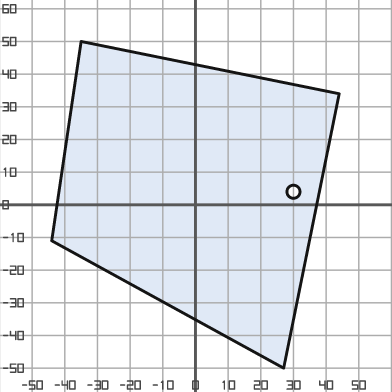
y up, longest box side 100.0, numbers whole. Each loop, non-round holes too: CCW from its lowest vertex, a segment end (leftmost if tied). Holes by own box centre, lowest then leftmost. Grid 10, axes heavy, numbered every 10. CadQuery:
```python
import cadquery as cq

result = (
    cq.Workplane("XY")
    .moveTo(27.0, -50.0)
    .lineTo(44.0, 34.0)
    .lineTo(-35.0, 50.0)
    .lineTo(-44.0, -11.0)
    .close()
    .moveTo(30.0, 4.0)
    .circle(2.0)
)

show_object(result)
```